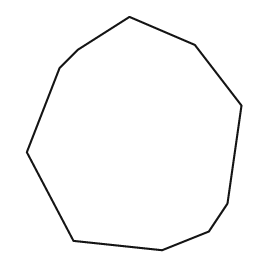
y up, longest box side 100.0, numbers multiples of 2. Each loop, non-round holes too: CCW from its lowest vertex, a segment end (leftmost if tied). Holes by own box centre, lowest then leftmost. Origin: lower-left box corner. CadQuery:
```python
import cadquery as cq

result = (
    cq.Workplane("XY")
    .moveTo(58.0, 0.0)
    .lineTo(78.0, 8.0)
    .lineTo(86.0, 20.0)
    .lineTo(92.0, 62.0)
    .lineTo(72.0, 88.0)
    .lineTo(44.0, 100.0)
    .lineTo(22.0, 86.0)
    .lineTo(14.0, 78.0)
    .lineTo(0.0, 42.0)
    .lineTo(20.0, 4.0)
    .close()
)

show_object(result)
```